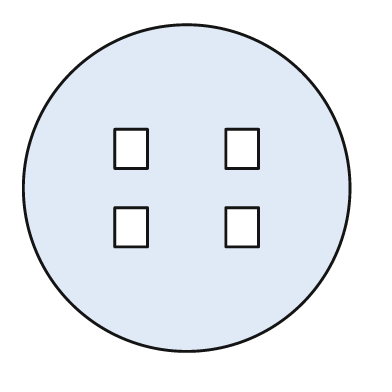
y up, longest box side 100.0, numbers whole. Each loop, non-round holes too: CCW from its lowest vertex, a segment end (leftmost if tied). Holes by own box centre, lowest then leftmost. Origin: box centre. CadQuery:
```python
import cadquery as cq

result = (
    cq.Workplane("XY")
    .moveTo(0.0, 0.0)
    .circle(50.0)
    .moveTo(-22.0, -18.0)
    .lineTo(-12.0, -18.0)
    .lineTo(-12.0, -6.0)
    .lineTo(-22.0, -6.0)
    .close()
    .moveTo(12.0, -18.0)
    .lineTo(22.0, -18.0)
    .lineTo(22.0, -6.0)
    .lineTo(12.0, -6.0)
    .close()
    .moveTo(-22.0, 6.0)
    .lineTo(-12.0, 6.0)
    .lineTo(-12.0, 18.0)
    .lineTo(-22.0, 18.0)
    .close()
    .moveTo(12.0, 6.0)
    .lineTo(22.0, 6.0)
    .lineTo(22.0, 18.0)
    .lineTo(12.0, 18.0)
    .close()
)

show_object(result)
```